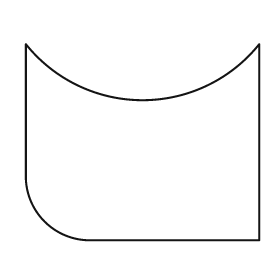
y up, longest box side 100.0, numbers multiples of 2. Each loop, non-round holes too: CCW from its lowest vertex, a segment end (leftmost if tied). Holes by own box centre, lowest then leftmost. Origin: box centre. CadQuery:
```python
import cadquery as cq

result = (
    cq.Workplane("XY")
    .moveTo(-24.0, -42.0)
    .lineTo(50.0, -42.0)
    .lineTo(50.0, 42.0)
    .threePointArc((0.0, 18.0), (-50.0, 42.0))
    .lineTo(-50.0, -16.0)
    .threePointArc((-42.0, -34.0), (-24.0, -42.0))
    .close()
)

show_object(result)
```